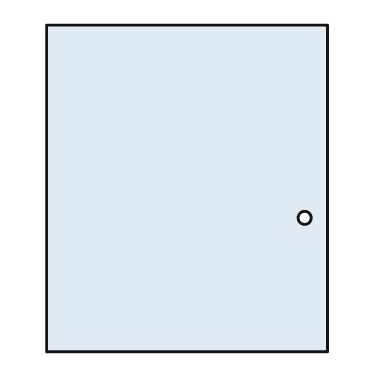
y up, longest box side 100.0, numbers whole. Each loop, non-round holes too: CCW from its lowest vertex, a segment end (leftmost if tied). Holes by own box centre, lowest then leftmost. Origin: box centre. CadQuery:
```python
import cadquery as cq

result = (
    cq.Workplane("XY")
    .moveTo(-43.0, -50.0)
    .lineTo(43.0, -50.0)
    .lineTo(43.0, 50.0)
    .lineTo(-43.0, 50.0)
    .close()
    .moveTo(36.0, -9.0)
    .circle(2.0)
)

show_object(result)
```